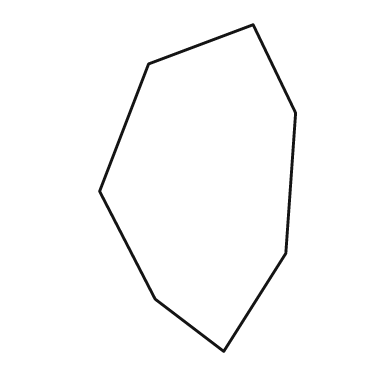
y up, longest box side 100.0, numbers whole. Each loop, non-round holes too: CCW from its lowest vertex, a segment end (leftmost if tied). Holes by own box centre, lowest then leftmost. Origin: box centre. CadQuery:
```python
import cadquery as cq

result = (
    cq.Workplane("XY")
    .moveTo(8.0, -50.0)
    .lineTo(27.0, -20.0)
    .lineTo(30.0, 23.0)
    .lineTo(17.0, 50.0)
    .lineTo(-15.0, 38.0)
    .lineTo(-30.0, -1.0)
    .lineTo(-13.0, -34.0)
    .close()
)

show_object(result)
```